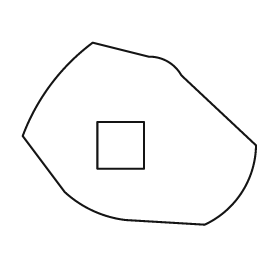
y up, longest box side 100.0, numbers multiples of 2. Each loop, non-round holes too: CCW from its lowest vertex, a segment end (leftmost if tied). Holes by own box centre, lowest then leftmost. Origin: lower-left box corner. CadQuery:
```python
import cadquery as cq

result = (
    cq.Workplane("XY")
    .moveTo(78.0, 0.0)
    .threePointArc((94.0, 14.0), (100.0, 34.0))
    .lineTo(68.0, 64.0)
    .threePointArc((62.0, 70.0), (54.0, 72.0))
    .lineTo(30.0, 78.0)
    .threePointArc((12.0, 60.0), (0.0, 38.0))
    .lineTo(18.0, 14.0)
    .threePointArc((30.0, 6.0), (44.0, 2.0))
    .close()
    .moveTo(32.0, 24.0)
    .lineTo(52.0, 24.0)
    .lineTo(52.0, 44.0)
    .lineTo(32.0, 44.0)
    .close()
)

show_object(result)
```